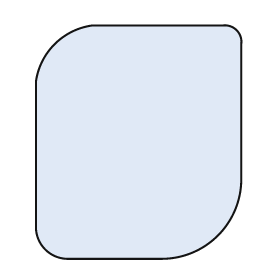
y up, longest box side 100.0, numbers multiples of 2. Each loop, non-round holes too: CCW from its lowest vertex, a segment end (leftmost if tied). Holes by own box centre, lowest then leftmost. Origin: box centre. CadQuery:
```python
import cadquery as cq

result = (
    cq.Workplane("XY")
    .moveTo(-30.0, -50.0)
    .lineTo(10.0, -50.0)
    .threePointArc((34.0, -40.0), (44.0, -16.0))
    .lineTo(44.0, 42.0)
    .threePointArc((42.0, 48.0), (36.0, 50.0))
    .lineTo(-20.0, 50.0)
    .threePointArc((-36.0, 42.0), (-44.0, 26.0))
    .lineTo(-44.0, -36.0)
    .threePointArc((-40.0, -46.0), (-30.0, -50.0))
    .close()
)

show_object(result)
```